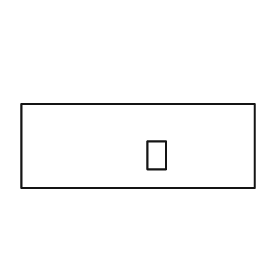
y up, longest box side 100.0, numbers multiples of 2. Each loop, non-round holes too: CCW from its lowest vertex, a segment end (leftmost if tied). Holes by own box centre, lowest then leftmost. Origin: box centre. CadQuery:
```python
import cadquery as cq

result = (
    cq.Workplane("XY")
    .moveTo(-50.0, -18.0)
    .lineTo(50.0, -18.0)
    .lineTo(50.0, 18.0)
    .lineTo(-50.0, 18.0)
    .close()
    .moveTo(4.0, -10.0)
    .lineTo(12.0, -10.0)
    .lineTo(12.0, 2.0)
    .lineTo(4.0, 2.0)
    .close()
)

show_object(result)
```